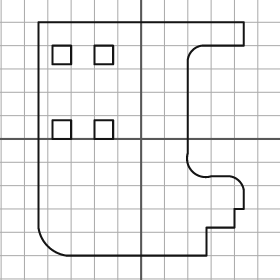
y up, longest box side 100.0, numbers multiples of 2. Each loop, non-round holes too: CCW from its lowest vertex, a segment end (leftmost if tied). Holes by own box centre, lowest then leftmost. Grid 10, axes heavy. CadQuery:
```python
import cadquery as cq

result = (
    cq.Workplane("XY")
    .moveTo(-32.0, -50.0)
    .lineTo(28.0, -50.0)
    .lineTo(28.0, -38.0)
    .lineTo(40.0, -38.0)
    .lineTo(40.0, -30.0)
    .lineTo(44.0, -30.0)
    .lineTo(44.0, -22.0)
    .threePointArc((42.0, -18.0), (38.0, -16.0))
    .lineTo(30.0, -16.0)
    .threePointArc((22.0, -14.0), (20.0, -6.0))
    .lineTo(20.0, 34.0)
    .threePointArc((22.0, 38.0), (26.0, 40.0))
    .lineTo(44.0, 40.0)
    .lineTo(44.0, 50.0)
    .lineTo(-44.0, 50.0)
    .lineTo(-44.0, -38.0)
    .threePointArc((-40.0, -46.0), (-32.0, -50.0))
    .close()
    .moveTo(-38.0, 0.0)
    .lineTo(-30.0, 0.0)
    .lineTo(-30.0, 8.0)
    .lineTo(-38.0, 8.0)
    .close()
    .moveTo(-20.0, 0.0)
    .lineTo(-12.0, 0.0)
    .lineTo(-12.0, 8.0)
    .lineTo(-20.0, 8.0)
    .close()
    .moveTo(-38.0, 32.0)
    .lineTo(-30.0, 32.0)
    .lineTo(-30.0, 40.0)
    .lineTo(-38.0, 40.0)
    .close()
    .moveTo(-20.0, 32.0)
    .lineTo(-12.0, 32.0)
    .lineTo(-12.0, 40.0)
    .lineTo(-20.0, 40.0)
    .close()
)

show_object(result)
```